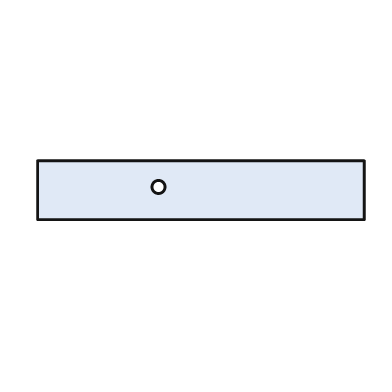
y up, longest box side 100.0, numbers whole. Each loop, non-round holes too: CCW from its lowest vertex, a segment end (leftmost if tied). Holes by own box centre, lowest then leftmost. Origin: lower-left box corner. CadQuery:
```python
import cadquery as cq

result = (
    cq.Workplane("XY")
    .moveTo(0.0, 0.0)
    .lineTo(100.0, 0.0)
    .lineTo(100.0, 18.0)
    .lineTo(0.0, 18.0)
    .close()
    .moveTo(37.0, 10.0)
    .circle(2.0)
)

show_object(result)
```